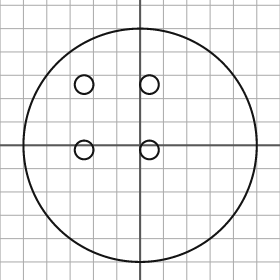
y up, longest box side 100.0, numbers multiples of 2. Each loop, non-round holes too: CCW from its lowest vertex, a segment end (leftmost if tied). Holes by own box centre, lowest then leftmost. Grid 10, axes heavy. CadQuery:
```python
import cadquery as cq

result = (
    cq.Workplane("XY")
    .moveTo(0.0, 0.0)
    .circle(50.0)
    .moveTo(-24.0, -2.0)
    .circle(4.0)
    .moveTo(4.0, -2.0)
    .circle(4.0)
    .moveTo(-24.0, 26.0)
    .circle(4.0)
    .moveTo(4.0, 26.0)
    .circle(4.0)
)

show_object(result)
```